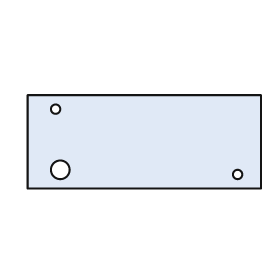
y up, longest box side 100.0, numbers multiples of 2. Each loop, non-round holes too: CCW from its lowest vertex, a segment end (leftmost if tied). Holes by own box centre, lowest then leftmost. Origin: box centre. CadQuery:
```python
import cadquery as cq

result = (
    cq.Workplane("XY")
    .moveTo(-50.0, -20.0)
    .lineTo(50.0, -20.0)
    .lineTo(50.0, 20.0)
    .lineTo(-50.0, 20.0)
    .close()
    .moveTo(40.0, -14.0)
    .circle(2.0)
    .moveTo(-36.0, -12.0)
    .circle(4.0)
    .moveTo(-38.0, 14.0)
    .circle(2.0)
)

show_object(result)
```